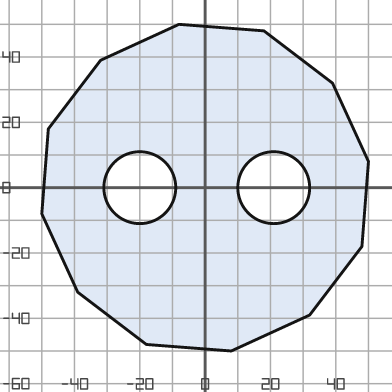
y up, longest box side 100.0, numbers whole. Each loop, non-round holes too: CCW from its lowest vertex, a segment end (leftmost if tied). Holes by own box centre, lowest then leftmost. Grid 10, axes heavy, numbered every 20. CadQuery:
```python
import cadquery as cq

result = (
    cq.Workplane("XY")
    .moveTo(8.0, -50.0)
    .lineTo(32.0, -39.0)
    .lineTo(48.0, -18.0)
    .lineTo(50.0, 8.0)
    .lineTo(39.0, 32.0)
    .lineTo(18.0, 48.0)
    .lineTo(-8.0, 50.0)
    .lineTo(-32.0, 39.0)
    .lineTo(-48.0, 18.0)
    .lineTo(-50.0, -8.0)
    .lineTo(-39.0, -32.0)
    .lineTo(-18.0, -48.0)
    .close()
    .moveTo(-20.0, 0.0)
    .circle(11.0)
    .moveTo(21.0, 0.0)
    .circle(11.0)
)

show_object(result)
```